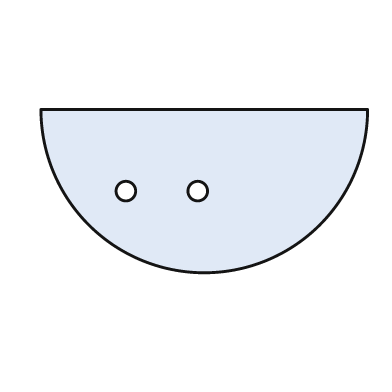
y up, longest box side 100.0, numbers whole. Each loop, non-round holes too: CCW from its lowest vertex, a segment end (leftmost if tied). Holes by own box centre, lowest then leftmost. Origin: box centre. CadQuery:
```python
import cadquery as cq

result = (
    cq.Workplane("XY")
    .moveTo(-50.0, 25.0)
    .threePointArc((0.0, -25.0), (50.0, 25.0))
    .close()
    .moveTo(-24.0, 0.0)
    .circle(3.0)
    .moveTo(-2.0, 0.0)
    .circle(3.0)
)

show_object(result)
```